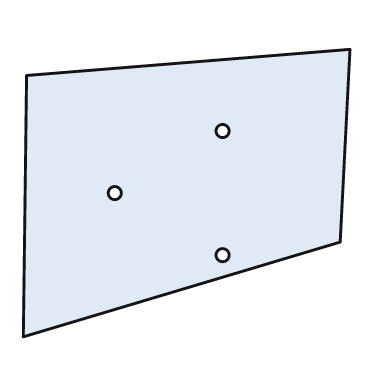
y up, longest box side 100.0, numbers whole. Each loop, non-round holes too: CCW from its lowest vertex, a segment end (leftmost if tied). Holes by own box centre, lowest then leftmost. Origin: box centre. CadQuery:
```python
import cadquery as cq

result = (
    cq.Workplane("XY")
    .moveTo(-50.0, -44.0)
    .lineTo(47.0, -15.0)
    .lineTo(50.0, 44.0)
    .lineTo(-49.0, 36.0)
    .close()
    .moveTo(11.0, -19.0)
    .circle(2.0)
    .moveTo(-22.0, 0.0)
    .circle(2.0)
    .moveTo(11.0, 19.0)
    .circle(2.0)
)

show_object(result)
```